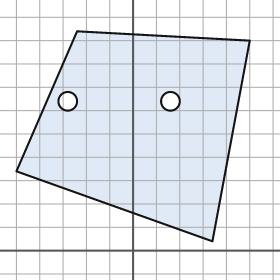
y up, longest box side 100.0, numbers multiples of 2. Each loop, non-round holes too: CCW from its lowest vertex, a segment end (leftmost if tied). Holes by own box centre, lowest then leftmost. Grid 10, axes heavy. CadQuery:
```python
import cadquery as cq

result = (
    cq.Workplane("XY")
    .moveTo(34.0, 4.0)
    .lineTo(50.0, 90.0)
    .lineTo(-24.0, 94.0)
    .lineTo(-50.0, 34.0)
    .close()
    .moveTo(-28.0, 64.0)
    .circle(4.0)
    .moveTo(16.0, 64.0)
    .circle(4.0)
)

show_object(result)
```